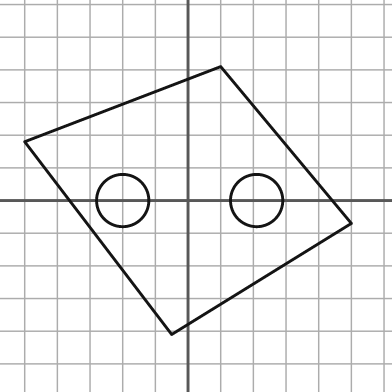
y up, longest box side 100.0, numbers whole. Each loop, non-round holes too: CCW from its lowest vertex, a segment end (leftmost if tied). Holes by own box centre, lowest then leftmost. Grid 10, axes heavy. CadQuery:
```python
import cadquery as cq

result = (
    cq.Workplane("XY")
    .moveTo(-5.0, -41.0)
    .lineTo(50.0, -7.0)
    .lineTo(10.0, 41.0)
    .lineTo(-50.0, 18.0)
    .close()
    .moveTo(-20.0, 0.0)
    .circle(8.0)
    .moveTo(21.0, 0.0)
    .circle(8.0)
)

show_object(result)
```